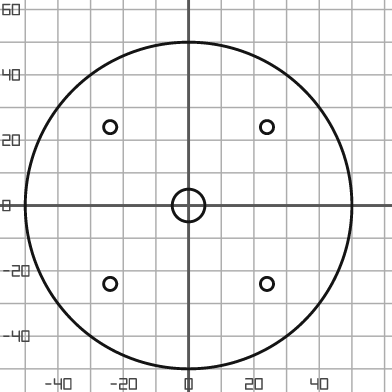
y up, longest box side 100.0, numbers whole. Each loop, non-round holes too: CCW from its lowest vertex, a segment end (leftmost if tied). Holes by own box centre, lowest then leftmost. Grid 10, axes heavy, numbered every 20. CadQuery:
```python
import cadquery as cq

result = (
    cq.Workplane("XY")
    .moveTo(0.0, 0.0)
    .circle(50.0)
    .moveTo(-24.0, -24.0)
    .circle(2.0)
    .moveTo(24.0, -24.0)
    .circle(2.0)
    .moveTo(0.0, 0.0)
    .circle(5.0)
    .moveTo(-24.0, 24.0)
    .circle(2.0)
    .moveTo(24.0, 24.0)
    .circle(2.0)
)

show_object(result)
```